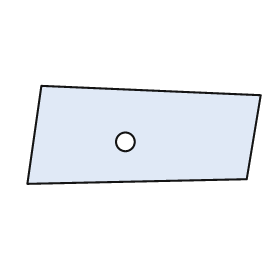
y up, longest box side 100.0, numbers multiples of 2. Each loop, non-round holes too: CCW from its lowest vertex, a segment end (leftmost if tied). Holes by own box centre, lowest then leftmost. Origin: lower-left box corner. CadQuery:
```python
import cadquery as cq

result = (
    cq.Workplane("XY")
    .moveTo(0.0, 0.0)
    .lineTo(94.0, 2.0)
    .lineTo(100.0, 38.0)
    .lineTo(6.0, 42.0)
    .close()
    .moveTo(42.0, 18.0)
    .circle(4.0)
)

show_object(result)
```